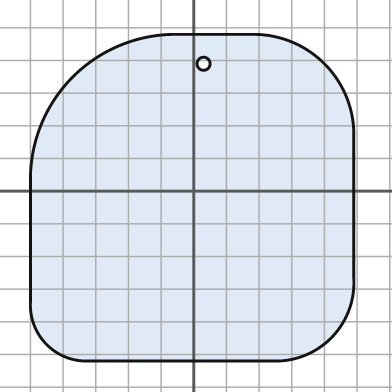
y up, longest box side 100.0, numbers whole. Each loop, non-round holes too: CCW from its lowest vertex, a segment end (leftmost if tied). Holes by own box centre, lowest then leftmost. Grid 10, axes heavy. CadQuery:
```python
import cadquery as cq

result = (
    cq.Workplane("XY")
    .moveTo(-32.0, -52.0)
    .lineTo(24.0, -52.0)
    .threePointArc((42.0, -45.0), (49.0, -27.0))
    .lineTo(49.0, 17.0)
    .threePointArc((40.0, 39.0), (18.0, 48.0))
    .lineTo(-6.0, 48.0)
    .threePointArc((-37.0, 35.0), (-50.0, 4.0))
    .lineTo(-50.0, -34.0)
    .threePointArc((-45.0, -47.0), (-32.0, -52.0))
    .close()
    .moveTo(3.0, 39.0)
    .circle(2.0)
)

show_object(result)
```